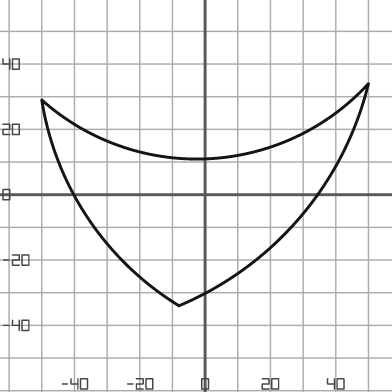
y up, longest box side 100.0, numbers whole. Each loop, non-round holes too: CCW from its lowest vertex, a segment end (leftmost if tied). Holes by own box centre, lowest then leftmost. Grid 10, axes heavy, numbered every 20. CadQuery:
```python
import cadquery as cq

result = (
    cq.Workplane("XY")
    .moveTo(-8.0, -34.0)
    .threePointArc((29.0, -7.0), (50.0, 34.0))
    .threePointArc((1.0, 11.0), (-50.0, 29.0))
    .threePointArc((-36.0, -7.0), (-8.0, -34.0))
    .close()
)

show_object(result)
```